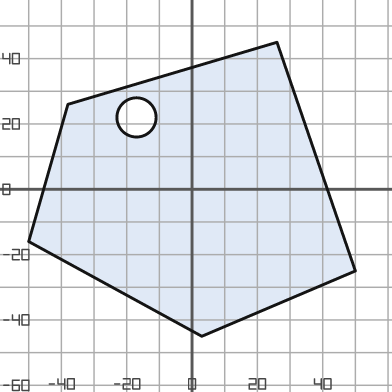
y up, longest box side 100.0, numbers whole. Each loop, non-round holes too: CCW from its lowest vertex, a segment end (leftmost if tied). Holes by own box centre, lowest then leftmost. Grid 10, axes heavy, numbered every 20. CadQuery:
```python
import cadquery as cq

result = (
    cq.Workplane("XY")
    .moveTo(3.0, -45.0)
    .lineTo(50.0, -25.0)
    .lineTo(26.0, 45.0)
    .lineTo(-38.0, 26.0)
    .lineTo(-50.0, -16.0)
    .close()
    .moveTo(-17.0, 22.0)
    .circle(6.0)
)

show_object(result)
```